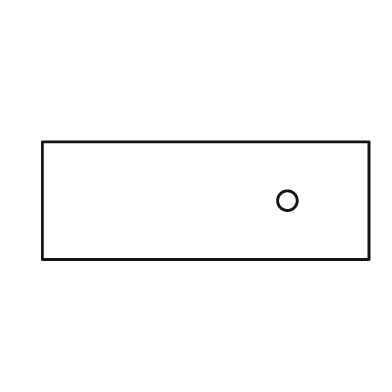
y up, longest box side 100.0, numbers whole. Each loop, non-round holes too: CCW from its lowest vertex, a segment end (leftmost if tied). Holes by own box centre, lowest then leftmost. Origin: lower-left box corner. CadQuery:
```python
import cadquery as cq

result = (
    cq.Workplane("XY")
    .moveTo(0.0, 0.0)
    .lineTo(100.0, 0.0)
    .lineTo(100.0, 36.0)
    .lineTo(0.0, 36.0)
    .close()
    .moveTo(75.0, 18.0)
    .circle(3.0)
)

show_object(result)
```